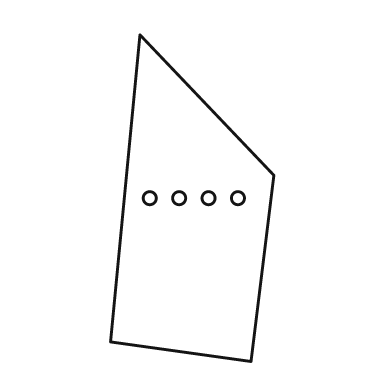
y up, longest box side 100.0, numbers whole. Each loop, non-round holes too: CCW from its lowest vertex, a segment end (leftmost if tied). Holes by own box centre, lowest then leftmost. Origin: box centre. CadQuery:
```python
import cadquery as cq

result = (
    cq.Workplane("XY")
    .moveTo(18.0, -50.0)
    .lineTo(25.0, 7.0)
    .lineTo(-16.0, 50.0)
    .lineTo(-25.0, -44.0)
    .close()
    .moveTo(-13.0, 0.0)
    .circle(2.0)
    .moveTo(-4.0, 0.0)
    .circle(2.0)
    .moveTo(5.0, 0.0)
    .circle(2.0)
    .moveTo(14.0, 0.0)
    .circle(2.0)
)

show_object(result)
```